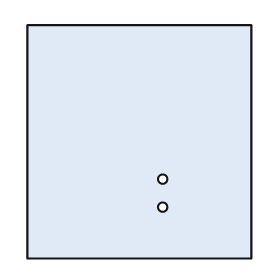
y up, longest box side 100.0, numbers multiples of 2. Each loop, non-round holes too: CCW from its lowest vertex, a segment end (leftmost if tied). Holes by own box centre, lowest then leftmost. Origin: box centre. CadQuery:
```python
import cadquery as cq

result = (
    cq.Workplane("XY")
    .moveTo(-48.0, -50.0)
    .lineTo(48.0, -50.0)
    .lineTo(48.0, 50.0)
    .lineTo(-48.0, 50.0)
    .close()
    .moveTo(10.0, -28.0)
    .circle(2.0)
    .moveTo(10.0, -16.0)
    .circle(2.0)
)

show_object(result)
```